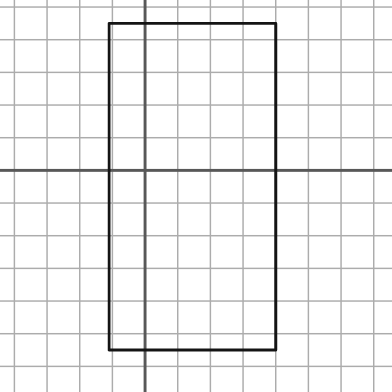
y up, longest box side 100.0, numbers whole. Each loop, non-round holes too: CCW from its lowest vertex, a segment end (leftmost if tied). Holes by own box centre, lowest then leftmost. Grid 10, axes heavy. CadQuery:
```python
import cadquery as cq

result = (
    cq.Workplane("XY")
    .moveTo(-11.0, -55.0)
    .lineTo(40.0, -55.0)
    .lineTo(40.0, 45.0)
    .lineTo(-11.0, 45.0)
    .close()
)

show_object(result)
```